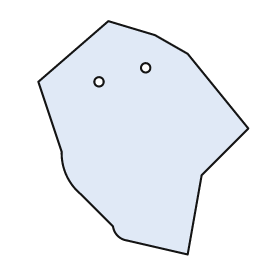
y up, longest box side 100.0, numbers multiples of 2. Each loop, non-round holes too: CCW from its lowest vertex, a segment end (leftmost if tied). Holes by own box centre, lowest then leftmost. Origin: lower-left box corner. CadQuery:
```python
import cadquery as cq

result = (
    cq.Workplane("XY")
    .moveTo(64.0, 0.0)
    .lineTo(70.0, 34.0)
    .lineTo(90.0, 54.0)
    .lineTo(64.0, 86.0)
    .lineTo(50.0, 94.0)
    .lineTo(30.0, 100.0)
    .lineTo(0.0, 74.0)
    .lineTo(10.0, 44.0)
    .threePointArc((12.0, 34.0), (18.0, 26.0))
    .lineTo(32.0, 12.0)
    .threePointArc((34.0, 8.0), (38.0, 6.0))
    .close()
    .moveTo(26.0, 74.0)
    .circle(2.0)
    .moveTo(46.0, 80.0)
    .circle(2.0)
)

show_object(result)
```